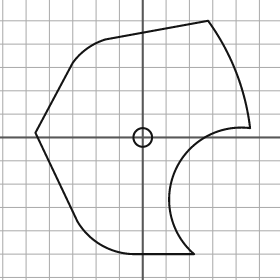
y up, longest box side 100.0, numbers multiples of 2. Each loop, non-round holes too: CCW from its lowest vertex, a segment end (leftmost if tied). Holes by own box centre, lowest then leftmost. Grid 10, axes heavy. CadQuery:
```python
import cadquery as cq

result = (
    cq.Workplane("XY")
    .moveTo(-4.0, -50.0)
    .lineTo(22.0, -50.0)
    .threePointArc((14.0, -14.0), (46.0, 4.0))
    .threePointArc((40.0, 28.0), (28.0, 50.0))
    .lineTo(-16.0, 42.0)
    .threePointArc((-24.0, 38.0), (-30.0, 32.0))
    .lineTo(-46.0, 2.0)
    .lineTo(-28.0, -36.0)
    .threePointArc((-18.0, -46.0), (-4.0, -50.0))
    .close()
    .moveTo(0.0, 0.0)
    .circle(4.0)
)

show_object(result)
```